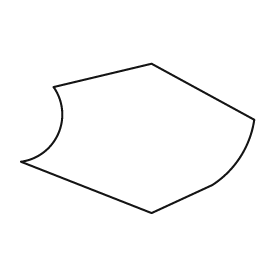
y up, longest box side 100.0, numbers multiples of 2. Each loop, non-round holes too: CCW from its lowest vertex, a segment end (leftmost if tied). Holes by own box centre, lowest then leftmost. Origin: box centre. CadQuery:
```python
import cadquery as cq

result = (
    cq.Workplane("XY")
    .moveTo(6.0, -32.0)
    .lineTo(32.0, -20.0)
    .threePointArc((44.0, -8.0), (50.0, 8.0))
    .lineTo(6.0, 32.0)
    .lineTo(-36.0, 22.0)
    .threePointArc((-34.0, 2.0), (-50.0, -10.0))
    .close()
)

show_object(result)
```